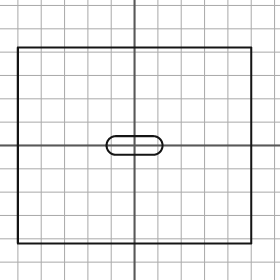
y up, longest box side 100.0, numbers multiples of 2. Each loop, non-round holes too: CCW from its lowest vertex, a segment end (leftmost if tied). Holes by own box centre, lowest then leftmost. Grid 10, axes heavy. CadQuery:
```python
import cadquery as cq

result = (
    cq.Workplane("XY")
    .moveTo(-50.0, -42.0)
    .lineTo(50.0, -42.0)
    .lineTo(50.0, 42.0)
    .lineTo(-50.0, 42.0)
    .close()
    .moveTo(-8.0, -4.0)
    .lineTo(8.0, -4.0)
    .threePointArc((12.0, 0.0), (8.0, 4.0))
    .lineTo(-8.0, 4.0)
    .threePointArc((-12.0, 0.0), (-8.0, -4.0))
    .close()
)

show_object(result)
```